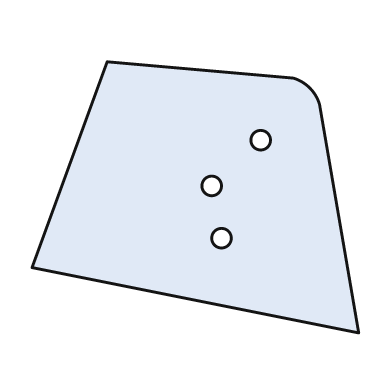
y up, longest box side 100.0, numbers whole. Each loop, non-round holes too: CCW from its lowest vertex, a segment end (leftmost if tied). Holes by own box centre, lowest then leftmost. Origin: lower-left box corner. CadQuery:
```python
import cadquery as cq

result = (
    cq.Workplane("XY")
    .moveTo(100.0, 0.0)
    .lineTo(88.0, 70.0)
    .threePointArc((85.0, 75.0), (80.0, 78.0))
    .lineTo(23.0, 83.0)
    .lineTo(0.0, 20.0)
    .close()
    .moveTo(58.0, 29.0)
    .circle(3.0)
    .moveTo(55.0, 45.0)
    .circle(3.0)
    .moveTo(70.0, 59.0)
    .circle(3.0)
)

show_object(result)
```